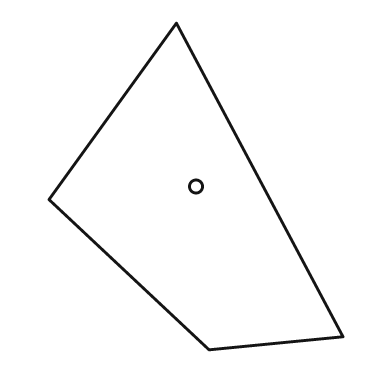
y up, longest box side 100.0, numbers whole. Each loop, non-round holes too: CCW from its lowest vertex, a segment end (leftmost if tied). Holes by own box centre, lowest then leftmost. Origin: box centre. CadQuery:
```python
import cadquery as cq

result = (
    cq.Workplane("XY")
    .moveTo(4.0, -50.0)
    .lineTo(45.0, -46.0)
    .lineTo(-6.0, 50.0)
    .lineTo(-45.0, -4.0)
    .close()
    .moveTo(0.0, 0.0)
    .circle(2.0)
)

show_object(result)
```